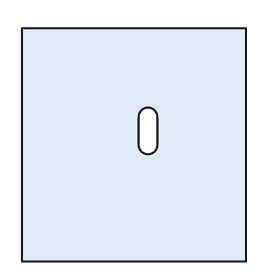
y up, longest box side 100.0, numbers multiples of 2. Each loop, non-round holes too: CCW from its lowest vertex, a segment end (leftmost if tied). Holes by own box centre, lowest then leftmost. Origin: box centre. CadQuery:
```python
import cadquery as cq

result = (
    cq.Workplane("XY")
    .moveTo(-48.0, -50.0)
    .lineTo(48.0, -50.0)
    .lineTo(48.0, 50.0)
    .lineTo(-48.0, 50.0)
    .close()
    .moveTo(2.0, 0.0)
    .threePointArc((6.0, -4.0), (10.0, 0.0))
    .lineTo(10.0, 12.0)
    .threePointArc((6.0, 16.0), (2.0, 12.0))
    .close()
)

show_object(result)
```